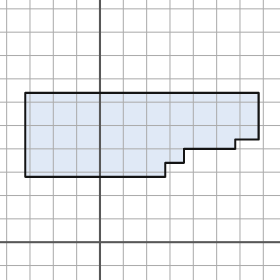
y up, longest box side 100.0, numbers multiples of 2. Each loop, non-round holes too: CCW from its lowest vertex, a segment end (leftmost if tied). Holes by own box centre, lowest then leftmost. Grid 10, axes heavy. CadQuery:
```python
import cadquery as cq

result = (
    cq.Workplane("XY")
    .moveTo(-32.0, 28.0)
    .lineTo(28.0, 28.0)
    .lineTo(28.0, 34.0)
    .lineTo(36.0, 34.0)
    .lineTo(36.0, 40.0)
    .lineTo(58.0, 40.0)
    .lineTo(58.0, 44.0)
    .lineTo(68.0, 44.0)
    .lineTo(68.0, 64.0)
    .lineTo(-32.0, 64.0)
    .close()
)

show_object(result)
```